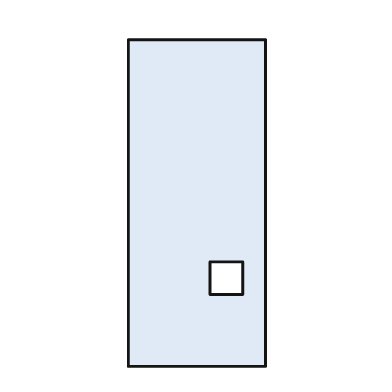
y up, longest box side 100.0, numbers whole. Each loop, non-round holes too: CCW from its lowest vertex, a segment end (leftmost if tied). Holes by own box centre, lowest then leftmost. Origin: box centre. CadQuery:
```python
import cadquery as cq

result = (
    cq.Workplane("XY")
    .moveTo(-21.0, -50.0)
    .lineTo(21.0, -50.0)
    .lineTo(21.0, 50.0)
    .lineTo(-21.0, 50.0)
    .close()
    .moveTo(4.0, -28.0)
    .lineTo(14.0, -28.0)
    .lineTo(14.0, -18.0)
    .lineTo(4.0, -18.0)
    .close()
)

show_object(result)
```